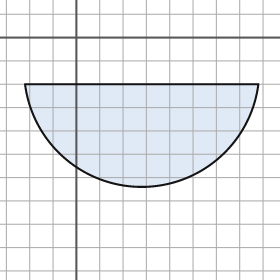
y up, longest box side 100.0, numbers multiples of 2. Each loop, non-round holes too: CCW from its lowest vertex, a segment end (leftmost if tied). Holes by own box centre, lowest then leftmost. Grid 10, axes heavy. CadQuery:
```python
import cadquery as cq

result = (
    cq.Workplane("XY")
    .moveTo(-22.0, -20.0)
    .threePointArc((28.0, -64.0), (78.0, -20.0))
    .close()
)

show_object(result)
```